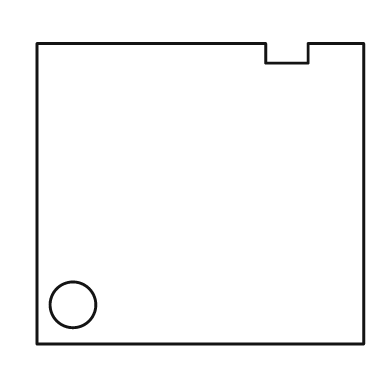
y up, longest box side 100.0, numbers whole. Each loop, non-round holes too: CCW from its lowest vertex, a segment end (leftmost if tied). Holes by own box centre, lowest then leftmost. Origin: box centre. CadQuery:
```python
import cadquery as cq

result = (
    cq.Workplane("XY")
    .moveTo(-50.0, -46.0)
    .lineTo(50.0, -46.0)
    .lineTo(50.0, 46.0)
    .lineTo(33.0, 46.0)
    .lineTo(33.0, 40.0)
    .lineTo(20.0, 40.0)
    .lineTo(20.0, 46.0)
    .lineTo(-50.0, 46.0)
    .close()
    .moveTo(-39.0, -34.0)
    .circle(7.0)
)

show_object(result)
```